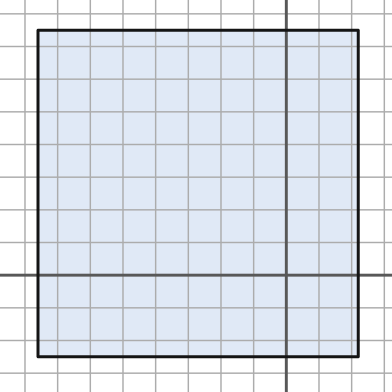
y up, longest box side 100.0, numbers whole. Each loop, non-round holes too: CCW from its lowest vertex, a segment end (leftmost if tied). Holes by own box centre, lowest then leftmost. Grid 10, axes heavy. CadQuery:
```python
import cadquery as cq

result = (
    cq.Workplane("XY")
    .moveTo(-76.0, -25.0)
    .lineTo(22.0, -25.0)
    .lineTo(22.0, 75.0)
    .lineTo(-76.0, 75.0)
    .close()
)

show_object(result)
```